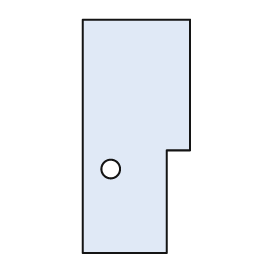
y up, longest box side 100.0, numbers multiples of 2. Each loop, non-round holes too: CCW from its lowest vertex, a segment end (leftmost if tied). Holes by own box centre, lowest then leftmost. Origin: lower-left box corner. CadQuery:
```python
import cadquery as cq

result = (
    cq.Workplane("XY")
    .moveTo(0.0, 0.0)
    .lineTo(36.0, 0.0)
    .lineTo(36.0, 44.0)
    .lineTo(46.0, 44.0)
    .lineTo(46.0, 100.0)
    .lineTo(0.0, 100.0)
    .close()
    .moveTo(12.0, 36.0)
    .circle(4.0)
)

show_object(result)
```